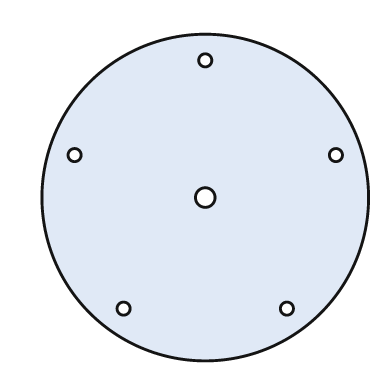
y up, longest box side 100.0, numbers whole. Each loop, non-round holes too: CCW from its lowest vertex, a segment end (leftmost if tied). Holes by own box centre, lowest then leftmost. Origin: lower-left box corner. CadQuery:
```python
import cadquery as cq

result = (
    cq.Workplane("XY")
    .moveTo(50.0, 50.0)
    .circle(50.0)
    .moveTo(25.0, 16.0)
    .circle(2.0)
    .moveTo(75.0, 16.0)
    .circle(2.0)
    .moveTo(50.0, 50.0)
    .circle(3.0)
    .moveTo(10.0, 63.0)
    .circle(2.0)
    .moveTo(90.0, 63.0)
    .circle(2.0)
    .moveTo(50.0, 92.0)
    .circle(2.0)
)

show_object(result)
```